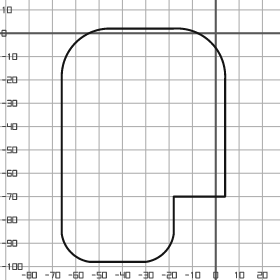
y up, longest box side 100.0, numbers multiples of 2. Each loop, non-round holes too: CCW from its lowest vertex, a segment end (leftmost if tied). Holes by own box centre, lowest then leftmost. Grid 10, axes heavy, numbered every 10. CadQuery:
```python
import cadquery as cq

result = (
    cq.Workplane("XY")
    .moveTo(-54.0, -98.0)
    .lineTo(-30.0, -98.0)
    .threePointArc((-22.0, -94.0), (-18.0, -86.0))
    .lineTo(-18.0, -70.0)
    .lineTo(4.0, -70.0)
    .lineTo(4.0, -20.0)
    .threePointArc((-2.0, -4.0), (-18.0, 2.0))
    .lineTo(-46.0, 2.0)
    .threePointArc((-60.0, -4.0), (-66.0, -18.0))
    .lineTo(-66.0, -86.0)
    .threePointArc((-62.0, -94.0), (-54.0, -98.0))
    .close()
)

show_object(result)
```